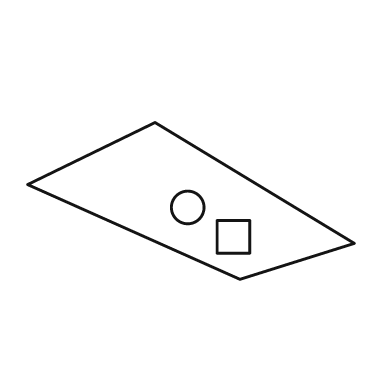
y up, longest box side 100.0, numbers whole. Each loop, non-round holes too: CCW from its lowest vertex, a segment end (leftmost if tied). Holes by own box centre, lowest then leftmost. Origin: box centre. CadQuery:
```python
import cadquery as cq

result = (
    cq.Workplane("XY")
    .moveTo(15.0, -24.0)
    .lineTo(50.0, -13.0)
    .lineTo(-11.0, 24.0)
    .lineTo(-50.0, 5.0)
    .close()
    .moveTo(8.0, -16.0)
    .lineTo(18.0, -16.0)
    .lineTo(18.0, -6.0)
    .lineTo(8.0, -6.0)
    .close()
    .moveTo(-1.0, -2.0)
    .circle(5.0)
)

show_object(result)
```